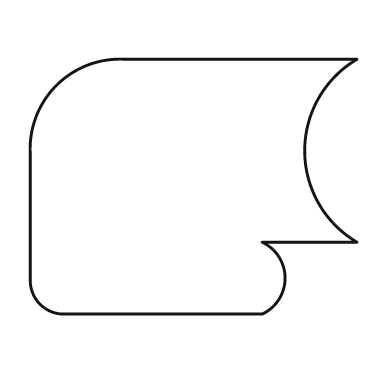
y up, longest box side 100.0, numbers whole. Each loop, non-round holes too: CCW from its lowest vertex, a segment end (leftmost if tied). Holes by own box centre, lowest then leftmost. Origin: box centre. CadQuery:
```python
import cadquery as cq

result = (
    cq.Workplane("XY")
    .moveTo(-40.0, -39.0)
    .lineTo(21.0, -39.0)
    .threePointArc((28.0, -28.0), (21.0, -17.0))
    .lineTo(50.0, -17.0)
    .threePointArc((34.0, 11.0), (50.0, 39.0))
    .lineTo(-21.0, 39.0)
    .threePointArc((-42.0, 31.0), (-50.0, 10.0))
    .lineTo(-50.0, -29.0)
    .threePointArc((-47.0, -36.0), (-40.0, -39.0))
    .close()
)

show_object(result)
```